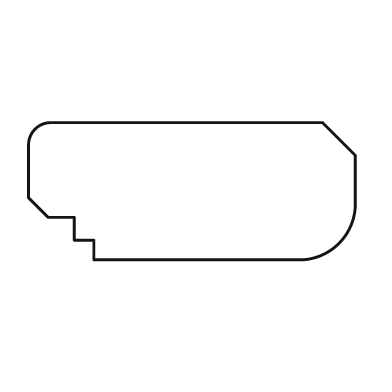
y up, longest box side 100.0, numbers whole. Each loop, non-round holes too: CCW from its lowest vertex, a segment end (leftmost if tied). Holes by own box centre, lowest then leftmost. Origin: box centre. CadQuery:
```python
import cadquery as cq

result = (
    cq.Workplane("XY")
    .moveTo(-30.0, -21.0)
    .lineTo(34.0, -21.0)
    .threePointArc((45.0, -16.0), (50.0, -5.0))
    .lineTo(50.0, 11.0)
    .lineTo(40.0, 21.0)
    .lineTo(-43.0, 21.0)
    .threePointArc((-48.0, 19.0), (-50.0, 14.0))
    .lineTo(-50.0, -2.0)
    .lineTo(-44.0, -8.0)
    .lineTo(-36.0, -8.0)
    .lineTo(-36.0, -15.0)
    .lineTo(-30.0, -15.0)
    .close()
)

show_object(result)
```